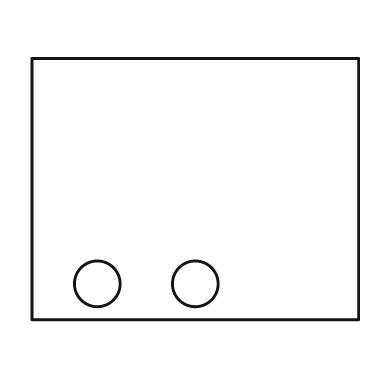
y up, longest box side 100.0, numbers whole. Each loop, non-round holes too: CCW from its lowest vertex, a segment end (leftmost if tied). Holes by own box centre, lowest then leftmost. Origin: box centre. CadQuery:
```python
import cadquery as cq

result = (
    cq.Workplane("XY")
    .moveTo(-50.0, -40.0)
    .lineTo(50.0, -40.0)
    .lineTo(50.0, 40.0)
    .lineTo(-50.0, 40.0)
    .close()
    .moveTo(-30.0, -29.0)
    .circle(7.0)
    .moveTo(0.0, -29.0)
    .circle(7.0)
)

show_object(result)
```